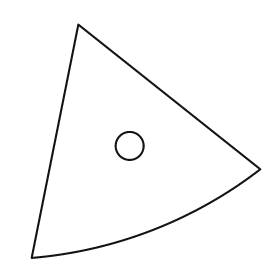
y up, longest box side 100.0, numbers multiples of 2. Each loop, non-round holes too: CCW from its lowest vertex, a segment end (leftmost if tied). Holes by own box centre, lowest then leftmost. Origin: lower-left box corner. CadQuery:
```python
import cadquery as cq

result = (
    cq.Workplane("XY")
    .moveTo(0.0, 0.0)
    .threePointArc((52.0, 12.0), (98.0, 38.0))
    .lineTo(20.0, 100.0)
    .close()
    .moveTo(42.0, 48.0)
    .circle(6.0)
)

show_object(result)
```